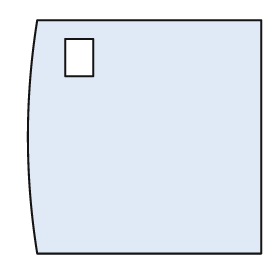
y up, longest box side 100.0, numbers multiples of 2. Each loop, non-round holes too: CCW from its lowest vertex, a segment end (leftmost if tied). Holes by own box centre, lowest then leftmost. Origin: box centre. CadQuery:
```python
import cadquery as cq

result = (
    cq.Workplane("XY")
    .moveTo(-46.0, -50.0)
    .lineTo(50.0, -50.0)
    .lineTo(50.0, 50.0)
    .lineTo(-46.0, 50.0)
    .threePointArc((-50.0, 0.0), (-46.0, -50.0))
    .close()
    .moveTo(-34.0, 26.0)
    .lineTo(-22.0, 26.0)
    .lineTo(-22.0, 42.0)
    .lineTo(-34.0, 42.0)
    .close()
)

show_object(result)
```